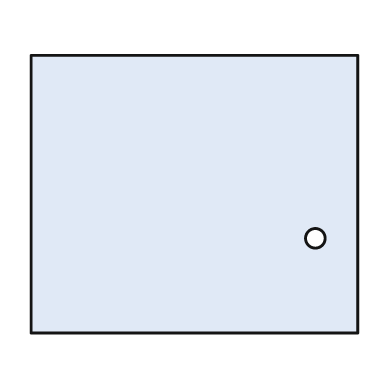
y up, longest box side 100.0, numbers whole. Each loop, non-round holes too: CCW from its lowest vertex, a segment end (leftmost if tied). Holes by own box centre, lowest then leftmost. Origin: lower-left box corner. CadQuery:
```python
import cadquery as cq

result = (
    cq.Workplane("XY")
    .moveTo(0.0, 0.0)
    .lineTo(100.0, 0.0)
    .lineTo(100.0, 85.0)
    .lineTo(0.0, 85.0)
    .close()
    .moveTo(87.0, 29.0)
    .circle(3.0)
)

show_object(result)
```